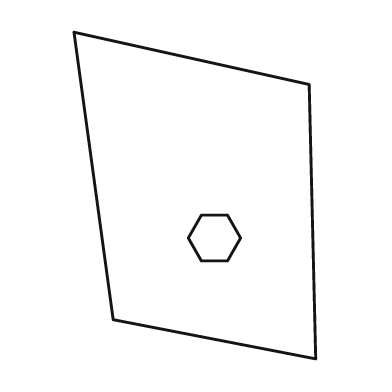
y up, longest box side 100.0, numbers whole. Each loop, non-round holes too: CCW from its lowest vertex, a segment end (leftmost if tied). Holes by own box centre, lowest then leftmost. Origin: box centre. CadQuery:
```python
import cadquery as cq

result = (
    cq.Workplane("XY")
    .moveTo(37.0, -50.0)
    .lineTo(35.0, 34.0)
    .lineTo(-37.0, 50.0)
    .lineTo(-25.0, -38.0)
    .close()
    .moveTo(2.0, -20.0)
    .lineTo(10.0, -20.0)
    .lineTo(14.0, -13.0)
    .lineTo(10.0, -6.0)
    .lineTo(2.0, -6.0)
    .lineTo(-2.0, -13.0)
    .close()
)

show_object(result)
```